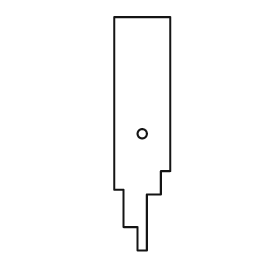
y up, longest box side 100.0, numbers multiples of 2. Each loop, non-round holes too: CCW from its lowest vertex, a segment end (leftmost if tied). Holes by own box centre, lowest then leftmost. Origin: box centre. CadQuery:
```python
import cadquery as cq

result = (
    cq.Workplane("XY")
    .moveTo(-2.0, -50.0)
    .lineTo(2.0, -50.0)
    .lineTo(2.0, -26.0)
    .lineTo(8.0, -26.0)
    .lineTo(8.0, -16.0)
    .lineTo(12.0, -16.0)
    .lineTo(12.0, 50.0)
    .lineTo(-12.0, 50.0)
    .lineTo(-12.0, -24.0)
    .lineTo(-8.0, -24.0)
    .lineTo(-8.0, -40.0)
    .lineTo(-2.0, -40.0)
    .close()
    .moveTo(0.0, 0.0)
    .circle(2.0)
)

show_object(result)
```